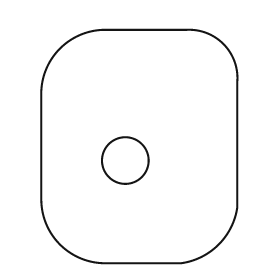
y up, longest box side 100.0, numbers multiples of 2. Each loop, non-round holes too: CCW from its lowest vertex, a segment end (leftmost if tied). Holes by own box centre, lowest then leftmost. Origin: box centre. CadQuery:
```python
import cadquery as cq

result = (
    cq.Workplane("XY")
    .moveTo(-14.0, -50.0)
    .lineTo(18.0, -50.0)
    .threePointArc((34.0, -42.0), (42.0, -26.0))
    .lineTo(42.0, 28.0)
    .threePointArc((36.0, 44.0), (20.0, 50.0))
    .lineTo(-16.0, 50.0)
    .threePointArc((-34.0, 42.0), (-42.0, 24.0))
    .lineTo(-42.0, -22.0)
    .threePointArc((-34.0, -42.0), (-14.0, -50.0))
    .close()
    .moveTo(-6.0, -6.0)
    .circle(10.0)
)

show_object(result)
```